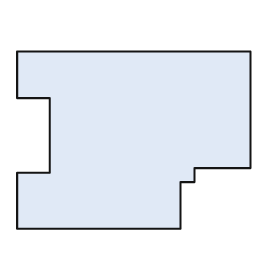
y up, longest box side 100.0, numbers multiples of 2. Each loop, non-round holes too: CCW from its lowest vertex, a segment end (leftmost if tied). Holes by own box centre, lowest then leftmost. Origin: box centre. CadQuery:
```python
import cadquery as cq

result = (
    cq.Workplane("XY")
    .moveTo(-50.0, -38.0)
    .lineTo(20.0, -38.0)
    .lineTo(20.0, -18.0)
    .lineTo(26.0, -18.0)
    .lineTo(26.0, -12.0)
    .lineTo(50.0, -12.0)
    .lineTo(50.0, 38.0)
    .lineTo(-50.0, 38.0)
    .lineTo(-50.0, 18.0)
    .lineTo(-36.0, 18.0)
    .lineTo(-36.0, -14.0)
    .lineTo(-50.0, -14.0)
    .close()
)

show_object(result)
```